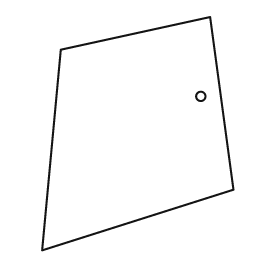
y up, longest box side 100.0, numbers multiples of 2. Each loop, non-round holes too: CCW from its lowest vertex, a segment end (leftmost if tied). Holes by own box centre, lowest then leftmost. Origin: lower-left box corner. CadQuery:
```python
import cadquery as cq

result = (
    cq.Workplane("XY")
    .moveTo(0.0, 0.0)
    .lineTo(82.0, 26.0)
    .lineTo(72.0, 100.0)
    .lineTo(8.0, 86.0)
    .close()
    .moveTo(68.0, 66.0)
    .circle(2.0)
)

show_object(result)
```